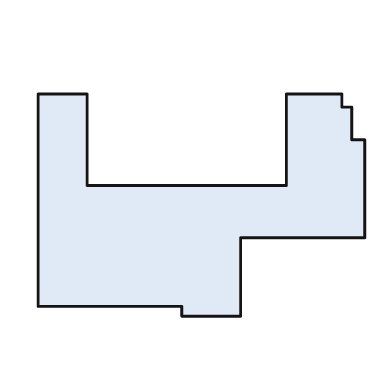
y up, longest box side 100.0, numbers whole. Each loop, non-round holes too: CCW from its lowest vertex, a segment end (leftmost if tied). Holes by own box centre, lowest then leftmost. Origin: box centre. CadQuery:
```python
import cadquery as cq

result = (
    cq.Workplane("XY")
    .moveTo(-6.0, -34.0)
    .lineTo(12.0, -34.0)
    .lineTo(12.0, -10.0)
    .lineTo(50.0, -10.0)
    .lineTo(50.0, 20.0)
    .lineTo(46.0, 20.0)
    .lineTo(46.0, 30.0)
    .lineTo(43.0, 30.0)
    .lineTo(43.0, 34.0)
    .lineTo(26.0, 34.0)
    .lineTo(26.0, 6.0)
    .lineTo(-35.0, 6.0)
    .lineTo(-35.0, 34.0)
    .lineTo(-50.0, 34.0)
    .lineTo(-50.0, -31.0)
    .lineTo(-6.0, -31.0)
    .close()
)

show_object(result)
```